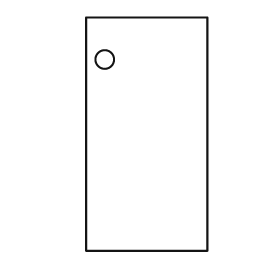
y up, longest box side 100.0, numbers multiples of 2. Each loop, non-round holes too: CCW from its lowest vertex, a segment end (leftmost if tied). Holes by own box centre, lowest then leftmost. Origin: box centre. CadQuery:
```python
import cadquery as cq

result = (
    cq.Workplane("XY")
    .moveTo(-26.0, -50.0)
    .lineTo(26.0, -50.0)
    .lineTo(26.0, 50.0)
    .lineTo(-26.0, 50.0)
    .close()
    .moveTo(-18.0, 32.0)
    .circle(4.0)
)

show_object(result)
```